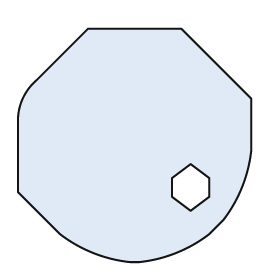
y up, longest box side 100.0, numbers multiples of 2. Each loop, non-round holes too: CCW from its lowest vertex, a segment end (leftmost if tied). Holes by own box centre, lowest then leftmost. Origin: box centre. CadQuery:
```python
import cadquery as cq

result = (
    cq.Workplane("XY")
    .moveTo(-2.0, -50.0)
    .lineTo(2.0, -50.0)
    .threePointArc((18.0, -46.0), (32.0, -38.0))
    .lineTo(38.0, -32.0)
    .threePointArc((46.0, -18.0), (50.0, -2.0))
    .lineTo(50.0, 20.0)
    .lineTo(20.0, 50.0)
    .lineTo(-20.0, 50.0)
    .lineTo(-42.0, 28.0)
    .threePointArc((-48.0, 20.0), (-50.0, 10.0))
    .lineTo(-50.0, -20.0)
    .lineTo(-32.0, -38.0)
    .threePointArc((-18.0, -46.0), (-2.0, -50.0))
    .close()
    .moveTo(24.0, -28.0)
    .lineTo(32.0, -22.0)
    .lineTo(32.0, -14.0)
    .lineTo(24.0, -8.0)
    .lineTo(16.0, -14.0)
    .lineTo(16.0, -22.0)
    .close()
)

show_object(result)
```